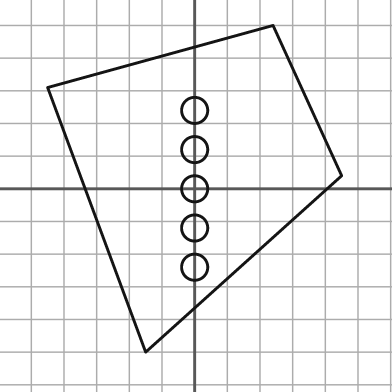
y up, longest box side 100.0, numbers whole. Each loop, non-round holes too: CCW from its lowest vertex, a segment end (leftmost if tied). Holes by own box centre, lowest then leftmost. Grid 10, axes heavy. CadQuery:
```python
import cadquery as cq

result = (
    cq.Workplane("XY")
    .moveTo(-15.0, -50.0)
    .lineTo(45.0, 4.0)
    .lineTo(24.0, 50.0)
    .lineTo(-45.0, 31.0)
    .close()
    .moveTo(0.0, -24.0)
    .circle(4.0)
    .moveTo(0.0, -12.0)
    .circle(4.0)
    .moveTo(0.0, 0.0)
    .circle(4.0)
    .moveTo(0.0, 12.0)
    .circle(4.0)
    .moveTo(0.0, 24.0)
    .circle(4.0)
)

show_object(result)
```